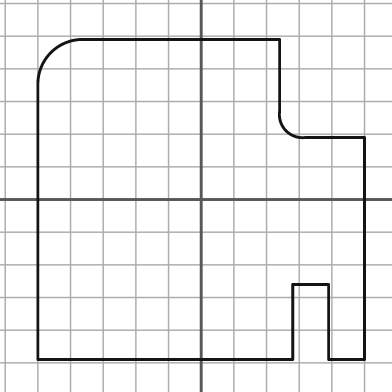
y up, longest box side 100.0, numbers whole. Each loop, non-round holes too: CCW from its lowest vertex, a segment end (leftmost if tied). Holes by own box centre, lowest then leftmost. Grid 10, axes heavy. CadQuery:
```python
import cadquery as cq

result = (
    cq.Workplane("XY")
    .moveTo(-50.0, -49.0)
    .lineTo(28.0, -49.0)
    .lineTo(28.0, -26.0)
    .lineTo(39.0, -26.0)
    .lineTo(39.0, -49.0)
    .lineTo(50.0, -49.0)
    .lineTo(50.0, 19.0)
    .lineTo(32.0, 19.0)
    .threePointArc((26.0, 21.0), (24.0, 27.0))
    .lineTo(24.0, 49.0)
    .lineTo(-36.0, 49.0)
    .threePointArc((-46.0, 45.0), (-50.0, 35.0))
    .close()
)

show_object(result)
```